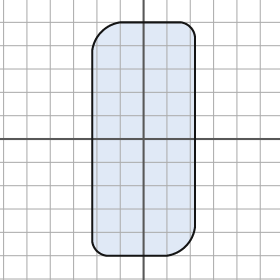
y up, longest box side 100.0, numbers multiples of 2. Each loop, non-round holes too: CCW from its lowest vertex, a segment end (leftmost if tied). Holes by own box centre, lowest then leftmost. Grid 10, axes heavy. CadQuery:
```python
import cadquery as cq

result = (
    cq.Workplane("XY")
    .moveTo(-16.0, -50.0)
    .lineTo(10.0, -50.0)
    .threePointArc((18.0, -46.0), (22.0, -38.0))
    .lineTo(22.0, 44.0)
    .threePointArc((20.0, 48.0), (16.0, 50.0))
    .lineTo(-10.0, 50.0)
    .threePointArc((-18.0, 46.0), (-22.0, 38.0))
    .lineTo(-22.0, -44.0)
    .threePointArc((-20.0, -48.0), (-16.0, -50.0))
    .close()
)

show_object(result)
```